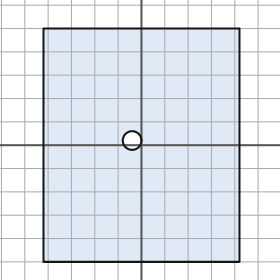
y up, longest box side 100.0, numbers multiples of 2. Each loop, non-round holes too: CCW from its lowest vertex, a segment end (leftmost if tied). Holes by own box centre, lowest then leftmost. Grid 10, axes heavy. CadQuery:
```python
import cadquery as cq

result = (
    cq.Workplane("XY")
    .moveTo(-42.0, -50.0)
    .lineTo(42.0, -50.0)
    .lineTo(42.0, 50.0)
    .lineTo(-42.0, 50.0)
    .close()
    .moveTo(-4.0, 2.0)
    .circle(4.0)
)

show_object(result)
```